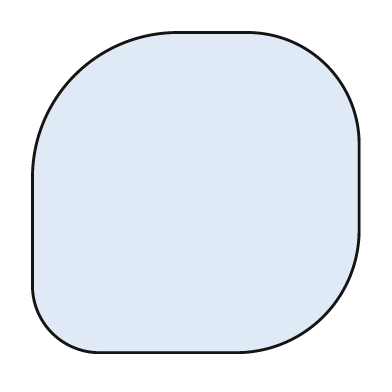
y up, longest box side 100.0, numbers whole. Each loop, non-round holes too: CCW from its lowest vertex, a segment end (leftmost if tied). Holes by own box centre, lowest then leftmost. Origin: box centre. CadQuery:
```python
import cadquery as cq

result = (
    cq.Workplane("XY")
    .moveTo(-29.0, -49.0)
    .lineTo(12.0, -49.0)
    .threePointArc((39.0, -38.0), (50.0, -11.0))
    .lineTo(50.0, 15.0)
    .threePointArc((40.0, 39.0), (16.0, 49.0))
    .lineTo(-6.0, 49.0)
    .threePointArc((-37.0, 36.0), (-50.0, 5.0))
    .lineTo(-50.0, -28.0)
    .threePointArc((-44.0, -43.0), (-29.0, -49.0))
    .close()
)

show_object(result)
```